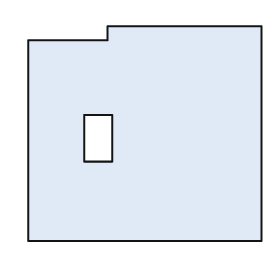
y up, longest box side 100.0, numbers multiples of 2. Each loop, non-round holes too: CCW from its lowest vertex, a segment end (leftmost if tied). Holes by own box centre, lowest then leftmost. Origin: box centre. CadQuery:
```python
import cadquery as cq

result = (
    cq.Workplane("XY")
    .moveTo(-50.0, -46.0)
    .lineTo(50.0, -46.0)
    .lineTo(50.0, 46.0)
    .lineTo(-16.0, 46.0)
    .lineTo(-16.0, 40.0)
    .lineTo(-50.0, 40.0)
    .close()
    .moveTo(-26.0, -12.0)
    .lineTo(-14.0, -12.0)
    .lineTo(-14.0, 8.0)
    .lineTo(-26.0, 8.0)
    .close()
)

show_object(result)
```